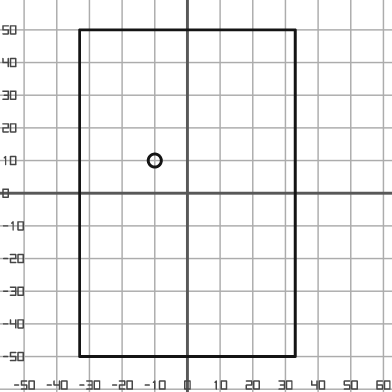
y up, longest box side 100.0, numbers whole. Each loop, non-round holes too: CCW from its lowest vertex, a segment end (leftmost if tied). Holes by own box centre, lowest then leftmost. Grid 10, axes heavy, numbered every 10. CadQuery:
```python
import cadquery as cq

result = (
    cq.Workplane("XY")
    .moveTo(-33.0, -50.0)
    .lineTo(33.0, -50.0)
    .lineTo(33.0, 50.0)
    .lineTo(-33.0, 50.0)
    .close()
    .moveTo(-10.0, 10.0)
    .circle(2.0)
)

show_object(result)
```